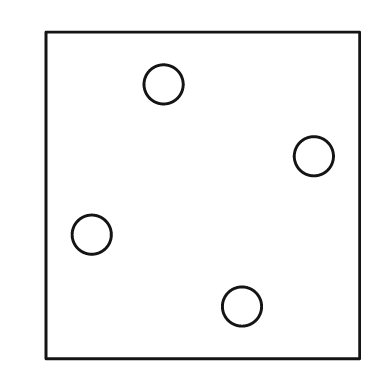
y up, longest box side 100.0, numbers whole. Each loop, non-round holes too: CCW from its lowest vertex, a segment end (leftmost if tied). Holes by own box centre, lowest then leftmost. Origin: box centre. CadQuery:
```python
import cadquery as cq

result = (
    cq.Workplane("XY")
    .moveTo(-48.0, -50.0)
    .lineTo(48.0, -50.0)
    .lineTo(48.0, 50.0)
    .lineTo(-48.0, 50.0)
    .close()
    .moveTo(12.0, -34.0)
    .circle(6.0)
    .moveTo(-34.0, -12.0)
    .circle(6.0)
    .moveTo(34.0, 12.0)
    .circle(6.0)
    .moveTo(-12.0, 34.0)
    .circle(6.0)
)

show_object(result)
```